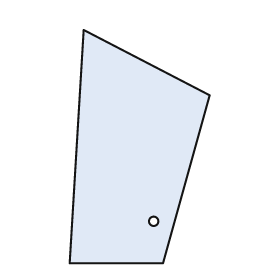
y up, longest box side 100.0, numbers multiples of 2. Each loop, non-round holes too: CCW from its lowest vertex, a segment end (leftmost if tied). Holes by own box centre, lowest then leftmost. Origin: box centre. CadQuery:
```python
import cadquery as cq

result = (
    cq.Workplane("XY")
    .moveTo(-30.0, -50.0)
    .lineTo(10.0, -50.0)
    .lineTo(30.0, 22.0)
    .lineTo(-24.0, 50.0)
    .close()
    .moveTo(6.0, -32.0)
    .circle(2.0)
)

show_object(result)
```